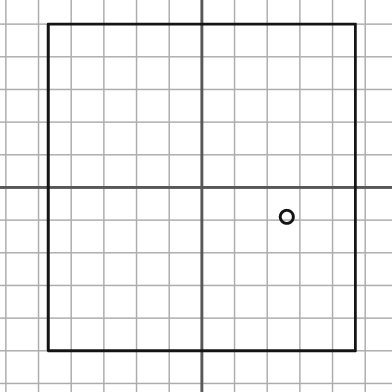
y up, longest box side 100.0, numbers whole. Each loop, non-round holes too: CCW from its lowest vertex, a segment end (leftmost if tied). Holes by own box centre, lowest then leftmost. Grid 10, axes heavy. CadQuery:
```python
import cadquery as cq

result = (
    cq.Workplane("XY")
    .moveTo(-47.0, -50.0)
    .lineTo(47.0, -50.0)
    .lineTo(47.0, 50.0)
    .lineTo(-47.0, 50.0)
    .close()
    .moveTo(26.0, -9.0)
    .circle(2.0)
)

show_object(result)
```